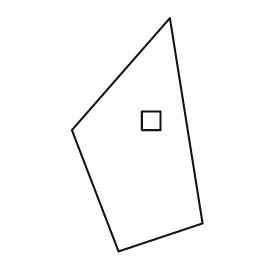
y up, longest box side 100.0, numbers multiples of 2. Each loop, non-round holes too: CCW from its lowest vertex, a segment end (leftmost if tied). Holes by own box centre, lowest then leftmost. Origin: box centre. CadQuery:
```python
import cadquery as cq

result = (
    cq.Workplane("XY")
    .moveTo(-8.0, -50.0)
    .lineTo(28.0, -38.0)
    .lineTo(14.0, 50.0)
    .lineTo(-28.0, 2.0)
    .close()
    .moveTo(2.0, 2.0)
    .lineTo(10.0, 2.0)
    .lineTo(10.0, 10.0)
    .lineTo(2.0, 10.0)
    .close()
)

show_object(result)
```